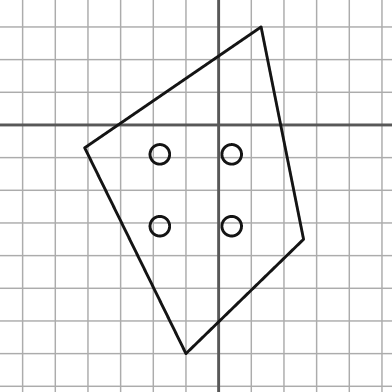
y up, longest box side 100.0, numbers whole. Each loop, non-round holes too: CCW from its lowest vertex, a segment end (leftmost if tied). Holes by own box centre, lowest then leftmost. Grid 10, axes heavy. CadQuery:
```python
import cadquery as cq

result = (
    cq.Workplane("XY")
    .moveTo(-10.0, -70.0)
    .lineTo(26.0, -35.0)
    .lineTo(13.0, 30.0)
    .lineTo(-41.0, -7.0)
    .close()
    .moveTo(-18.0, -31.0)
    .circle(3.0)
    .moveTo(4.0, -31.0)
    .circle(3.0)
    .moveTo(-18.0, -9.0)
    .circle(3.0)
    .moveTo(4.0, -9.0)
    .circle(3.0)
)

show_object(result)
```